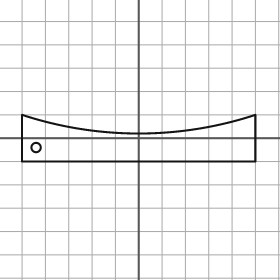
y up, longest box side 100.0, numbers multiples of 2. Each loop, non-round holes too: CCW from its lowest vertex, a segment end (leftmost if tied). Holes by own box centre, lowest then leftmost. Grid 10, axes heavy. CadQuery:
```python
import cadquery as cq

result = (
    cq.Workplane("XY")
    .moveTo(-50.0, -10.0)
    .lineTo(50.0, -10.0)
    .lineTo(50.0, 10.0)
    .threePointArc((0.0, 2.0), (-50.0, 10.0))
    .close()
    .moveTo(-44.0, -4.0)
    .circle(2.0)
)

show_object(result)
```